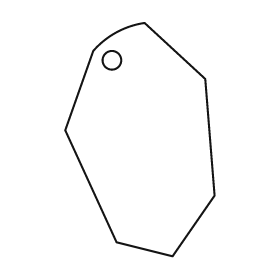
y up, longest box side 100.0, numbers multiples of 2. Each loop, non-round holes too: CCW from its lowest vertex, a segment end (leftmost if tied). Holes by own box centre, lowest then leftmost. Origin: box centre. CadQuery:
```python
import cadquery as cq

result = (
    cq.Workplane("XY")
    .moveTo(14.0, -50.0)
    .lineTo(32.0, -24.0)
    .lineTo(28.0, 26.0)
    .lineTo(2.0, 50.0)
    .threePointArc((-10.0, 46.0), (-20.0, 38.0))
    .lineTo(-32.0, 4.0)
    .lineTo(-10.0, -44.0)
    .close()
    .moveTo(-12.0, 34.0)
    .circle(4.0)
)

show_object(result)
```